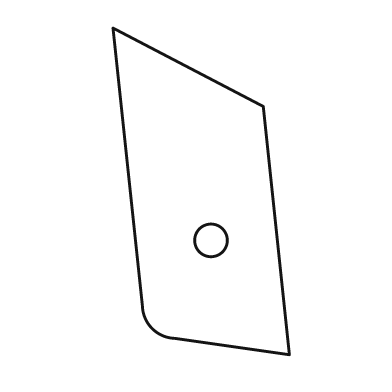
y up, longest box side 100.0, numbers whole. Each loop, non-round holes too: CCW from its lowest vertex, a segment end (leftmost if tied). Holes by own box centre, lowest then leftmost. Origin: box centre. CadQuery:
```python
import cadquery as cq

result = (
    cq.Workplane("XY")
    .moveTo(27.0, -50.0)
    .lineTo(19.0, 26.0)
    .lineTo(-27.0, 50.0)
    .lineTo(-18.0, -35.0)
    .threePointArc((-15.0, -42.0), (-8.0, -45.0))
    .close()
    .moveTo(3.0, -15.0)
    .circle(5.0)
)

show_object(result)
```